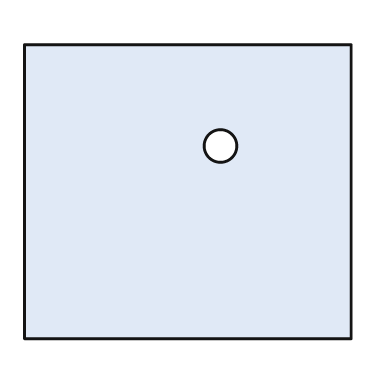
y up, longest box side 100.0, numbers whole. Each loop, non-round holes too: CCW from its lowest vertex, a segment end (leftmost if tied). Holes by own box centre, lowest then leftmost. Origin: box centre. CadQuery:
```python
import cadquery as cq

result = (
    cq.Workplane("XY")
    .moveTo(-50.0, -45.0)
    .lineTo(50.0, -45.0)
    .lineTo(50.0, 45.0)
    .lineTo(-50.0, 45.0)
    .close()
    .moveTo(10.0, 14.0)
    .circle(5.0)
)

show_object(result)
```